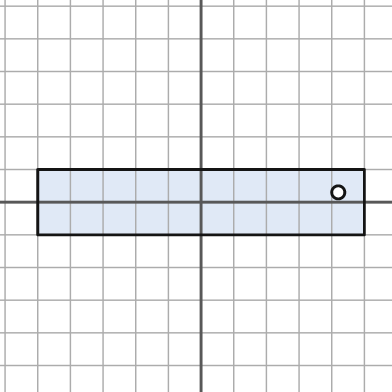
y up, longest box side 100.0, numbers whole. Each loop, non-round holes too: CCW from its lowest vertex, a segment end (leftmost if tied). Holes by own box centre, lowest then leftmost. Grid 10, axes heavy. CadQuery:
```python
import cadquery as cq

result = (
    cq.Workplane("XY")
    .moveTo(-50.0, -10.0)
    .lineTo(50.0, -10.0)
    .lineTo(50.0, 10.0)
    .lineTo(-50.0, 10.0)
    .close()
    .moveTo(42.0, 3.0)
    .circle(2.0)
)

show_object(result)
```